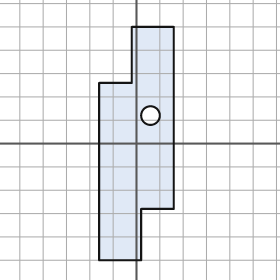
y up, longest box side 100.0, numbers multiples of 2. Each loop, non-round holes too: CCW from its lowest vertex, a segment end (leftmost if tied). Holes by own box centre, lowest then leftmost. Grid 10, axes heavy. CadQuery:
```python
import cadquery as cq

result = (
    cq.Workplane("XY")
    .moveTo(-16.0, -50.0)
    .lineTo(2.0, -50.0)
    .lineTo(2.0, -28.0)
    .lineTo(16.0, -28.0)
    .lineTo(16.0, 50.0)
    .lineTo(-2.0, 50.0)
    .lineTo(-2.0, 26.0)
    .lineTo(-16.0, 26.0)
    .close()
    .moveTo(6.0, 12.0)
    .circle(4.0)
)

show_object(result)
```